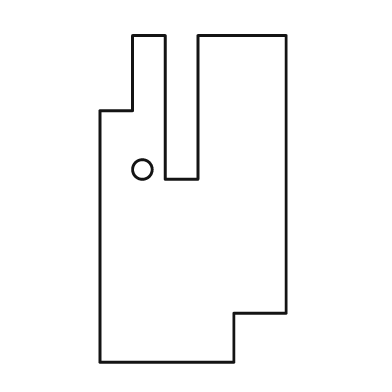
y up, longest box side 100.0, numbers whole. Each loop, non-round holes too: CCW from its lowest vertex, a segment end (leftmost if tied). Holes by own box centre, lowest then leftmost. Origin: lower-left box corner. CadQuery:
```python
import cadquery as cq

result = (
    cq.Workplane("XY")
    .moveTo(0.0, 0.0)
    .lineTo(41.0, 0.0)
    .lineTo(41.0, 15.0)
    .lineTo(57.0, 15.0)
    .lineTo(57.0, 100.0)
    .lineTo(30.0, 100.0)
    .lineTo(30.0, 56.0)
    .lineTo(20.0, 56.0)
    .lineTo(20.0, 100.0)
    .lineTo(10.0, 100.0)
    .lineTo(10.0, 77.0)
    .lineTo(0.0, 77.0)
    .close()
    .moveTo(13.0, 59.0)
    .circle(3.0)
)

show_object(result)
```